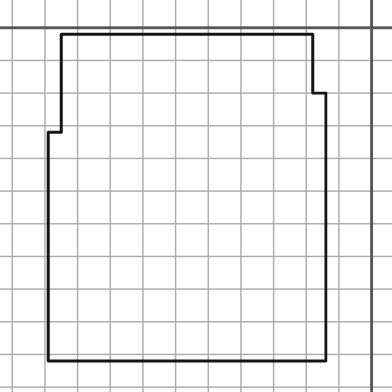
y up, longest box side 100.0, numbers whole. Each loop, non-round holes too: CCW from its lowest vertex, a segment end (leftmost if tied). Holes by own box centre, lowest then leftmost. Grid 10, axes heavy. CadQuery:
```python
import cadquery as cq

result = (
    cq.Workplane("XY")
    .moveTo(-99.0, -102.0)
    .lineTo(-14.0, -102.0)
    .lineTo(-14.0, -20.0)
    .lineTo(-18.0, -20.0)
    .lineTo(-18.0, -2.0)
    .lineTo(-95.0, -2.0)
    .lineTo(-95.0, -32.0)
    .lineTo(-99.0, -32.0)
    .close()
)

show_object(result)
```